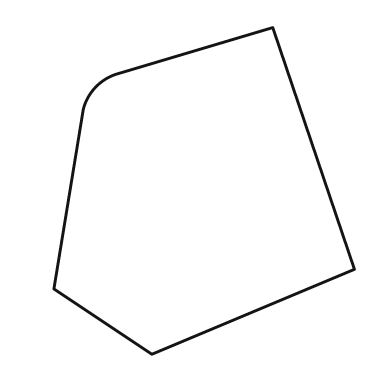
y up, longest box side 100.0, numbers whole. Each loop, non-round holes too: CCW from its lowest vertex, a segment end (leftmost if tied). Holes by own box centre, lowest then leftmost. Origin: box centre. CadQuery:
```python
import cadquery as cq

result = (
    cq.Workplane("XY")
    .moveTo(-16.0, -50.0)
    .lineTo(46.0, -24.0)
    .lineTo(21.0, 50.0)
    .lineTo(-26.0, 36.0)
    .threePointArc((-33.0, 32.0), (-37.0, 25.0))
    .lineTo(-46.0, -30.0)
    .close()
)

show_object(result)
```